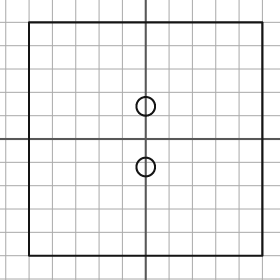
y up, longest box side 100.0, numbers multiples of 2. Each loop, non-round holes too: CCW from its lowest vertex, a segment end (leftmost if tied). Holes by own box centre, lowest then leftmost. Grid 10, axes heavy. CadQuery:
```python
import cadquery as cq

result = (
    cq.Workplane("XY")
    .moveTo(-50.0, -50.0)
    .lineTo(50.0, -50.0)
    .lineTo(50.0, 50.0)
    .lineTo(-50.0, 50.0)
    .close()
    .moveTo(0.0, -12.0)
    .circle(4.0)
    .moveTo(0.0, 14.0)
    .circle(4.0)
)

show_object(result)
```